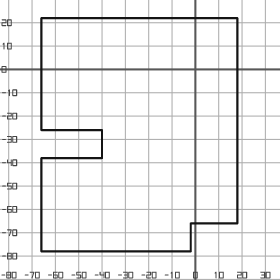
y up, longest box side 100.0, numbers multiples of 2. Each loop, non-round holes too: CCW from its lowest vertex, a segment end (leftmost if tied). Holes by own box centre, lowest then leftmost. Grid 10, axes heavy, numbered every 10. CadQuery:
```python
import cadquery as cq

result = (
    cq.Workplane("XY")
    .moveTo(-66.0, -78.0)
    .lineTo(-2.0, -78.0)
    .lineTo(-2.0, -66.0)
    .lineTo(18.0, -66.0)
    .lineTo(18.0, 22.0)
    .lineTo(-66.0, 22.0)
    .lineTo(-66.0, -26.0)
    .lineTo(-40.0, -26.0)
    .lineTo(-40.0, -38.0)
    .lineTo(-66.0, -38.0)
    .close()
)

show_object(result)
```